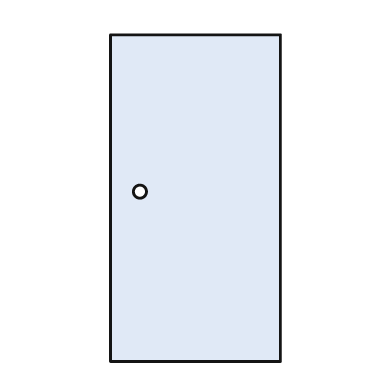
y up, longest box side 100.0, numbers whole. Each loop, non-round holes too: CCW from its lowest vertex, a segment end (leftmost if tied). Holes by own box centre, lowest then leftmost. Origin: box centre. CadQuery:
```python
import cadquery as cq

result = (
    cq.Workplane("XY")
    .moveTo(-26.0, -50.0)
    .lineTo(26.0, -50.0)
    .lineTo(26.0, 50.0)
    .lineTo(-26.0, 50.0)
    .close()
    .moveTo(-17.0, 2.0)
    .circle(2.0)
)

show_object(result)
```